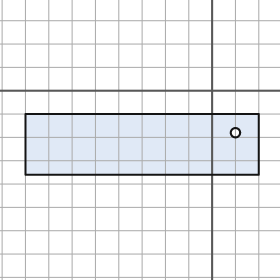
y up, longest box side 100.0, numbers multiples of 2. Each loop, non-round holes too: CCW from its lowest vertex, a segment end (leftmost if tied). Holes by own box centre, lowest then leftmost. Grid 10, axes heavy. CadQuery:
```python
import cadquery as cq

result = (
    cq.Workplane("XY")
    .moveTo(-80.0, -36.0)
    .lineTo(20.0, -36.0)
    .lineTo(20.0, -10.0)
    .lineTo(-80.0, -10.0)
    .close()
    .moveTo(10.0, -18.0)
    .circle(2.0)
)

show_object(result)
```